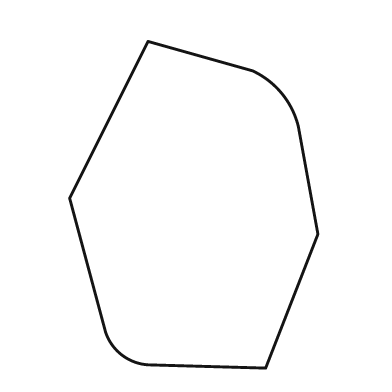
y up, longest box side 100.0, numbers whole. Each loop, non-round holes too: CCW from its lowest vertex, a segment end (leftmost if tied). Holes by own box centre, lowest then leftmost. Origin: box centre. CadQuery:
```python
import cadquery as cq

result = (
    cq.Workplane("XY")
    .moveTo(22.0, -50.0)
    .lineTo(38.0, -9.0)
    .lineTo(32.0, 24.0)
    .threePointArc((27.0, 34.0), (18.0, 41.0))
    .lineTo(-14.0, 50.0)
    .lineTo(-38.0, 2.0)
    .lineTo(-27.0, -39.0)
    .threePointArc((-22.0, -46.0), (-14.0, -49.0))
    .close()
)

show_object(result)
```